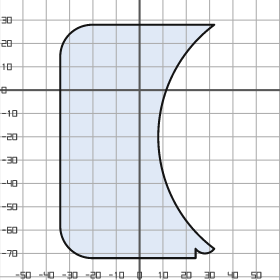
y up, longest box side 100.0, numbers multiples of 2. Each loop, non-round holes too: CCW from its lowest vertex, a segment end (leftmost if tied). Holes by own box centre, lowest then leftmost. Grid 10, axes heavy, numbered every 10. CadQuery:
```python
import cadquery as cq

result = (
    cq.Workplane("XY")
    .moveTo(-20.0, -72.0)
    .lineTo(24.0, -72.0)
    .lineTo(24.0, -68.0)
    .threePointArc((28.0, -70.0), (32.0, -68.0))
    .threePointArc((8.0, -20.0), (32.0, 28.0))
    .lineTo(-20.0, 28.0)
    .threePointArc((-30.0, 24.0), (-34.0, 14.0))
    .lineTo(-34.0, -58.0)
    .threePointArc((-30.0, -68.0), (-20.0, -72.0))
    .close()
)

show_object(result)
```